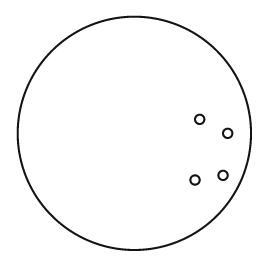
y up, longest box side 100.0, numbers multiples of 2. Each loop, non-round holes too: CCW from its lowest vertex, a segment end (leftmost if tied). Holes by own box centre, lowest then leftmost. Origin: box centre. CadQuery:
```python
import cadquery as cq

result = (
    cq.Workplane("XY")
    .moveTo(0.0, 0.0)
    .circle(50.0)
    .moveTo(26.0, -20.0)
    .circle(2.0)
    .moveTo(38.0, -18.0)
    .circle(2.0)
    .moveTo(40.0, 0.0)
    .circle(2.0)
    .moveTo(28.0, 6.0)
    .circle(2.0)
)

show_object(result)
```